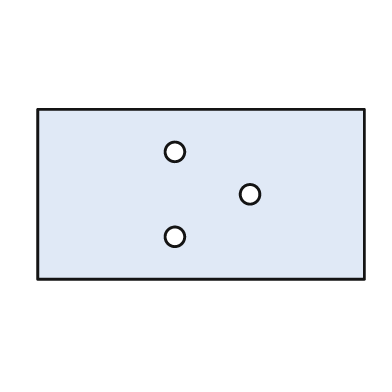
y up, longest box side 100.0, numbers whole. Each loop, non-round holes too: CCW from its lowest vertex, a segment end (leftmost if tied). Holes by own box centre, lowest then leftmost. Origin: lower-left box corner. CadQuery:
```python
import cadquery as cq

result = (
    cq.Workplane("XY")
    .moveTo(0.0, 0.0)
    .lineTo(100.0, 0.0)
    .lineTo(100.0, 52.0)
    .lineTo(0.0, 52.0)
    .close()
    .moveTo(42.0, 13.0)
    .circle(3.0)
    .moveTo(65.0, 26.0)
    .circle(3.0)
    .moveTo(42.0, 39.0)
    .circle(3.0)
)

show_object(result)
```